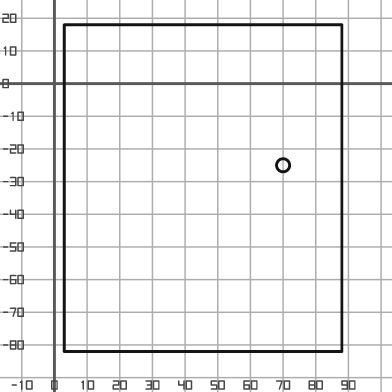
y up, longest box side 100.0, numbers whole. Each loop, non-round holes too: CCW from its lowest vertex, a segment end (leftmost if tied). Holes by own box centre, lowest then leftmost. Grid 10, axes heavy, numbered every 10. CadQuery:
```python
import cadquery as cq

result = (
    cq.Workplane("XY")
    .moveTo(3.0, -82.0)
    .lineTo(88.0, -82.0)
    .lineTo(88.0, 18.0)
    .lineTo(3.0, 18.0)
    .close()
    .moveTo(70.0, -25.0)
    .circle(2.0)
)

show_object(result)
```